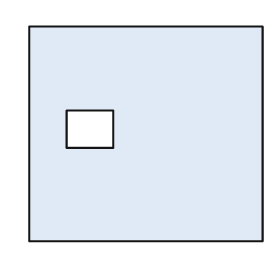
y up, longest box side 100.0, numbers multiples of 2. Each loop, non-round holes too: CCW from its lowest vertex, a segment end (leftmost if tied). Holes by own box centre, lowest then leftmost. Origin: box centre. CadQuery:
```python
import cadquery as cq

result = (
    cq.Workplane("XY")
    .moveTo(-50.0, -46.0)
    .lineTo(50.0, -46.0)
    .lineTo(50.0, 46.0)
    .lineTo(-50.0, 46.0)
    .close()
    .moveTo(-34.0, -6.0)
    .lineTo(-14.0, -6.0)
    .lineTo(-14.0, 10.0)
    .lineTo(-34.0, 10.0)
    .close()
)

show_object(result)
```